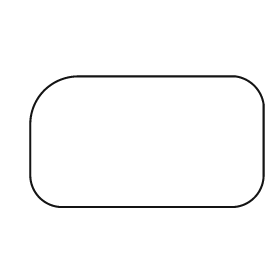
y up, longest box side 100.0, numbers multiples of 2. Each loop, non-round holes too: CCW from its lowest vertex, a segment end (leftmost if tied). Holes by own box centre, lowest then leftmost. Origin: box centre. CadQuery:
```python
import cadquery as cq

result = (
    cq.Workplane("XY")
    .moveTo(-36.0, -28.0)
    .lineTo(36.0, -28.0)
    .threePointArc((46.0, -24.0), (50.0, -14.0))
    .lineTo(50.0, 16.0)
    .threePointArc((46.0, 24.0), (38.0, 28.0))
    .lineTo(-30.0, 28.0)
    .threePointArc((-44.0, 22.0), (-50.0, 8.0))
    .lineTo(-50.0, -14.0)
    .threePointArc((-46.0, -24.0), (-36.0, -28.0))
    .close()
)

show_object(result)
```